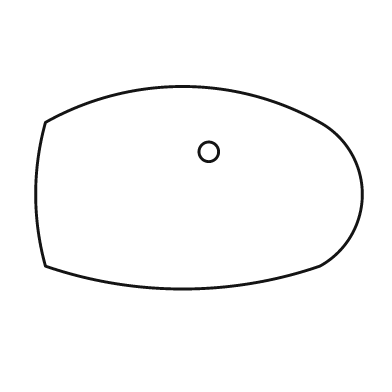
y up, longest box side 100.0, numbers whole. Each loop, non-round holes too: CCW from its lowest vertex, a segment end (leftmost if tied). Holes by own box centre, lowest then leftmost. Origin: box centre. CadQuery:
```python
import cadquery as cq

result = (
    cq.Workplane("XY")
    .moveTo(-47.0, -24.0)
    .threePointArc((-5.0, -31.0), (37.0, -24.0))
    .threePointArc((50.0, -2.0), (37.0, 20.0))
    .threePointArc((-5.0, 31.0), (-47.0, 20.0))
    .threePointArc((-50.0, -2.0), (-47.0, -24.0))
    .close()
    .moveTo(3.0, 11.0)
    .circle(3.0)
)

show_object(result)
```